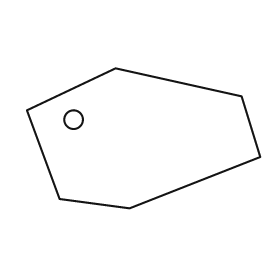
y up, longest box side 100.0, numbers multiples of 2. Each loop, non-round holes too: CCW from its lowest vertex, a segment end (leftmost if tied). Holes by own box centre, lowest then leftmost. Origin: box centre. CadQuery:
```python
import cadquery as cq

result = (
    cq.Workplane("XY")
    .moveTo(-6.0, -30.0)
    .lineTo(50.0, -8.0)
    .lineTo(42.0, 18.0)
    .lineTo(-12.0, 30.0)
    .lineTo(-50.0, 12.0)
    .lineTo(-36.0, -26.0)
    .close()
    .moveTo(-30.0, 8.0)
    .circle(4.0)
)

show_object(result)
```